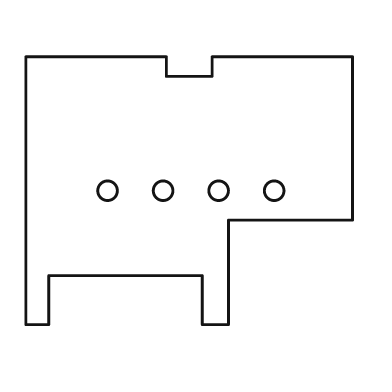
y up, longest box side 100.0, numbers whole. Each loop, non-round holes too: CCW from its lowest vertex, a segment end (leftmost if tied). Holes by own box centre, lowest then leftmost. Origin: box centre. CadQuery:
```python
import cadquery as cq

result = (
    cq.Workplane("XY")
    .moveTo(-50.0, -41.0)
    .lineTo(-43.0, -41.0)
    .lineTo(-43.0, -26.0)
    .lineTo(4.0, -26.0)
    .lineTo(4.0, -41.0)
    .lineTo(12.0, -41.0)
    .lineTo(12.0, -9.0)
    .lineTo(50.0, -9.0)
    .lineTo(50.0, 41.0)
    .lineTo(7.0, 41.0)
    .lineTo(7.0, 35.0)
    .lineTo(-7.0, 35.0)
    .lineTo(-7.0, 41.0)
    .lineTo(-50.0, 41.0)
    .close()
    .moveTo(-25.0, 0.0)
    .circle(3.0)
    .moveTo(-8.0, 0.0)
    .circle(3.0)
    .moveTo(9.0, 0.0)
    .circle(3.0)
    .moveTo(26.0, 0.0)
    .circle(3.0)
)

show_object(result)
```